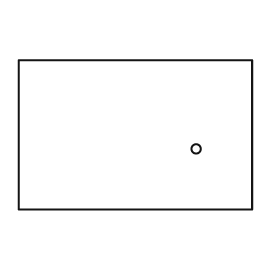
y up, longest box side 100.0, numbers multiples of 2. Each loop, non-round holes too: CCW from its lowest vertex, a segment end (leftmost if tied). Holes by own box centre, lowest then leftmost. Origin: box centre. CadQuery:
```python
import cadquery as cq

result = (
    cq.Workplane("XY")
    .moveTo(-50.0, -32.0)
    .lineTo(50.0, -32.0)
    .lineTo(50.0, 32.0)
    .lineTo(-50.0, 32.0)
    .close()
    .moveTo(26.0, -6.0)
    .circle(2.0)
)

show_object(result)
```